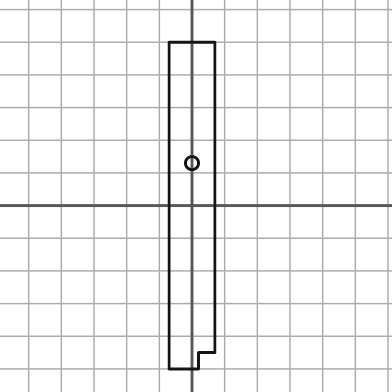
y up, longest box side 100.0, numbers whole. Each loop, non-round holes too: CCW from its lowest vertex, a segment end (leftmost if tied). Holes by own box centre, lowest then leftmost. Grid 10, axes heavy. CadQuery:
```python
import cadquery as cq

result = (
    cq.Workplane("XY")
    .moveTo(-7.0, -50.0)
    .lineTo(2.0, -50.0)
    .lineTo(2.0, -45.0)
    .lineTo(7.0, -45.0)
    .lineTo(7.0, 50.0)
    .lineTo(-7.0, 50.0)
    .close()
    .moveTo(0.0, 13.0)
    .circle(2.0)
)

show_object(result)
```